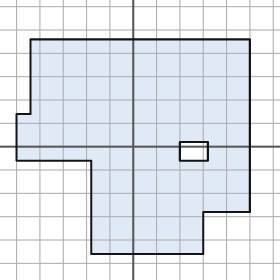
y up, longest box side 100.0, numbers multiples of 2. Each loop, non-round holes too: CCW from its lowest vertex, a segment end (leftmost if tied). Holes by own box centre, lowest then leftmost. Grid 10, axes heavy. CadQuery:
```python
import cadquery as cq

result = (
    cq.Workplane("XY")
    .moveTo(-18.0, -46.0)
    .lineTo(30.0, -46.0)
    .lineTo(30.0, -28.0)
    .lineTo(50.0, -28.0)
    .lineTo(50.0, 46.0)
    .lineTo(-44.0, 46.0)
    .lineTo(-44.0, 14.0)
    .lineTo(-50.0, 14.0)
    .lineTo(-50.0, -6.0)
    .lineTo(-18.0, -6.0)
    .close()
    .moveTo(20.0, -6.0)
    .lineTo(32.0, -6.0)
    .lineTo(32.0, 2.0)
    .lineTo(20.0, 2.0)
    .close()
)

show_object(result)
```